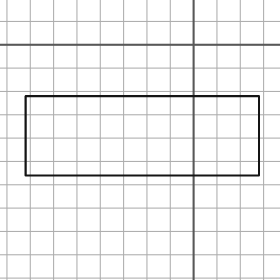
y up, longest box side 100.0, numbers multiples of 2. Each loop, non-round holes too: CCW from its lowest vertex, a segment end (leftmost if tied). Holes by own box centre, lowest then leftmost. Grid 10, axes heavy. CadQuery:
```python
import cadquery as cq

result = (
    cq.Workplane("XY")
    .moveTo(-72.0, -56.0)
    .lineTo(28.0, -56.0)
    .lineTo(28.0, -22.0)
    .lineTo(-72.0, -22.0)
    .close()
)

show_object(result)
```